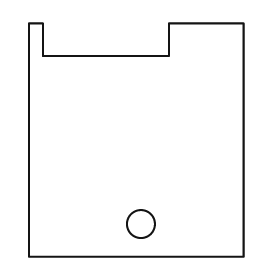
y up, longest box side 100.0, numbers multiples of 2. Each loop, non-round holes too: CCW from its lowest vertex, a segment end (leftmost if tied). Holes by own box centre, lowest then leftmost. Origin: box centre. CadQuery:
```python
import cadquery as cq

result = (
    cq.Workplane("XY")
    .moveTo(-46.0, -50.0)
    .lineTo(46.0, -50.0)
    .lineTo(46.0, 50.0)
    .lineTo(14.0, 50.0)
    .lineTo(14.0, 36.0)
    .lineTo(-40.0, 36.0)
    .lineTo(-40.0, 50.0)
    .lineTo(-46.0, 50.0)
    .close()
    .moveTo(2.0, -36.0)
    .circle(6.0)
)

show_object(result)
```